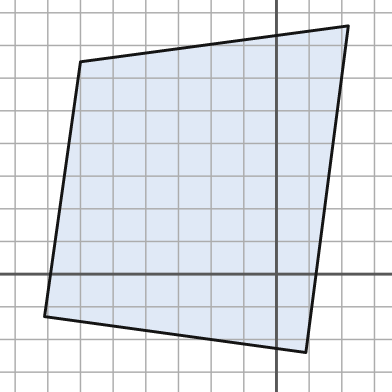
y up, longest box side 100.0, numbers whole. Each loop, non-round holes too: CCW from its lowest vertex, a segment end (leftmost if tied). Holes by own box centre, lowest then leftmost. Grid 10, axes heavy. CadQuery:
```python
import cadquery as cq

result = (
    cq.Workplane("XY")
    .moveTo(9.0, -24.0)
    .lineTo(22.0, 76.0)
    .lineTo(-60.0, 65.0)
    .lineTo(-71.0, -13.0)
    .close()
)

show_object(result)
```